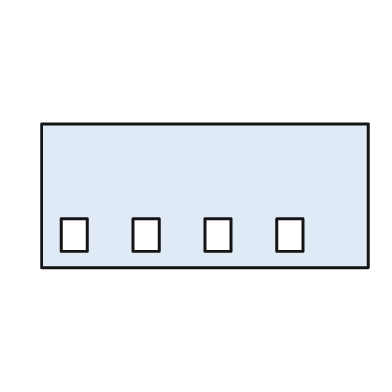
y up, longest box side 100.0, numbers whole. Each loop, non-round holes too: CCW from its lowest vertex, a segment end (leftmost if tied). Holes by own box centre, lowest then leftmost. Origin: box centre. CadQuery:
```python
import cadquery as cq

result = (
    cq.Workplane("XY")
    .moveTo(-50.0, -22.0)
    .lineTo(50.0, -22.0)
    .lineTo(50.0, 22.0)
    .lineTo(-50.0, 22.0)
    .close()
    .moveTo(-44.0, -17.0)
    .lineTo(-36.0, -17.0)
    .lineTo(-36.0, -7.0)
    .lineTo(-44.0, -7.0)
    .close()
    .moveTo(-22.0, -17.0)
    .lineTo(-14.0, -17.0)
    .lineTo(-14.0, -7.0)
    .lineTo(-22.0, -7.0)
    .close()
    .moveTo(0.0, -17.0)
    .lineTo(8.0, -17.0)
    .lineTo(8.0, -7.0)
    .lineTo(0.0, -7.0)
    .close()
    .moveTo(22.0, -17.0)
    .lineTo(30.0, -17.0)
    .lineTo(30.0, -7.0)
    .lineTo(22.0, -7.0)
    .close()
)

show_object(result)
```